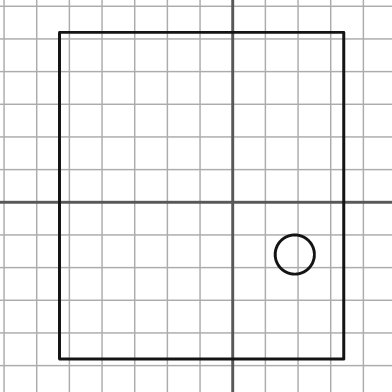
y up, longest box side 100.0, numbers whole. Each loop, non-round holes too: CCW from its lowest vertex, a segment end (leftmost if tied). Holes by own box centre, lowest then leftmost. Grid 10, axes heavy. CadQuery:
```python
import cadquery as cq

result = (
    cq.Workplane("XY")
    .moveTo(-53.0, -48.0)
    .lineTo(34.0, -48.0)
    .lineTo(34.0, 52.0)
    .lineTo(-53.0, 52.0)
    .close()
    .moveTo(19.0, -16.0)
    .circle(6.0)
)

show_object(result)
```